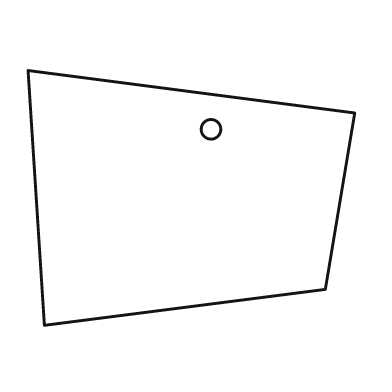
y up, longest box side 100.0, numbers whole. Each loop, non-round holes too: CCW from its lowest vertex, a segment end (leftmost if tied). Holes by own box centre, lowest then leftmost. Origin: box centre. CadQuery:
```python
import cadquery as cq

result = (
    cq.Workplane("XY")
    .moveTo(-45.0, -39.0)
    .lineTo(41.0, -28.0)
    .lineTo(50.0, 26.0)
    .lineTo(-50.0, 39.0)
    .close()
    .moveTo(6.0, 21.0)
    .circle(3.0)
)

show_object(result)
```